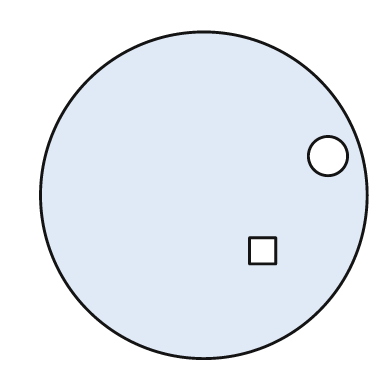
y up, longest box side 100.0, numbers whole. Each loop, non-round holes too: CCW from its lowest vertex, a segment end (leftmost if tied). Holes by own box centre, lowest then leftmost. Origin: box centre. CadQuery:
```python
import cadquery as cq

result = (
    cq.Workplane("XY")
    .moveTo(0.0, 0.0)
    .circle(50.0)
    .moveTo(14.0, -21.0)
    .lineTo(22.0, -21.0)
    .lineTo(22.0, -13.0)
    .lineTo(14.0, -13.0)
    .close()
    .moveTo(38.0, 12.0)
    .circle(6.0)
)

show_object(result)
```